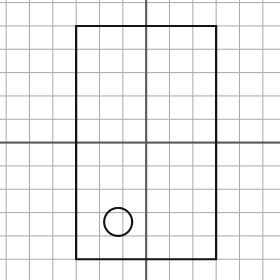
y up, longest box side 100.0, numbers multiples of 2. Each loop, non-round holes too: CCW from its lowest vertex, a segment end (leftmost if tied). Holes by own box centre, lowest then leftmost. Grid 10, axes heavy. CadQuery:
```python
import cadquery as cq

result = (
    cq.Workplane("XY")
    .moveTo(-30.0, -50.0)
    .lineTo(30.0, -50.0)
    .lineTo(30.0, 50.0)
    .lineTo(-30.0, 50.0)
    .close()
    .moveTo(-12.0, -34.0)
    .circle(6.0)
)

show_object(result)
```